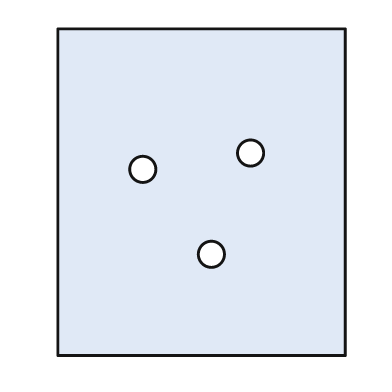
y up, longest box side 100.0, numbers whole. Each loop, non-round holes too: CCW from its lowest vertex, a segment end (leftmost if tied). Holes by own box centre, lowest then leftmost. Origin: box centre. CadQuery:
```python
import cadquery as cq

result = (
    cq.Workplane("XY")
    .moveTo(-44.0, -50.0)
    .lineTo(44.0, -50.0)
    .lineTo(44.0, 50.0)
    .lineTo(-44.0, 50.0)
    .close()
    .moveTo(3.0, -19.0)
    .circle(4.0)
    .moveTo(-18.0, 7.0)
    .circle(4.0)
    .moveTo(15.0, 12.0)
    .circle(4.0)
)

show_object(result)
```